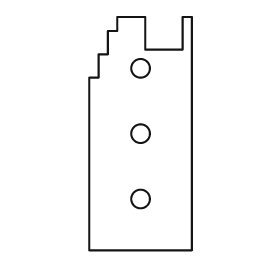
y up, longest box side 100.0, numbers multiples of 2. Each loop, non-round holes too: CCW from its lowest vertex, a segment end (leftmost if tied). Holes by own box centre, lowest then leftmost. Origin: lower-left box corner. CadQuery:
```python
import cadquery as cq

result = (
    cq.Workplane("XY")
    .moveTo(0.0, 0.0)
    .lineTo(44.0, 0.0)
    .lineTo(44.0, 100.0)
    .lineTo(40.0, 100.0)
    .lineTo(40.0, 86.0)
    .lineTo(24.0, 86.0)
    .lineTo(24.0, 100.0)
    .lineTo(12.0, 100.0)
    .lineTo(12.0, 94.0)
    .lineTo(8.0, 94.0)
    .lineTo(8.0, 84.0)
    .lineTo(4.0, 84.0)
    .lineTo(4.0, 74.0)
    .lineTo(0.0, 74.0)
    .close()
    .moveTo(22.0, 22.0)
    .circle(4.0)
    .moveTo(22.0, 50.0)
    .circle(4.0)
    .moveTo(22.0, 78.0)
    .circle(4.0)
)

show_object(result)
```